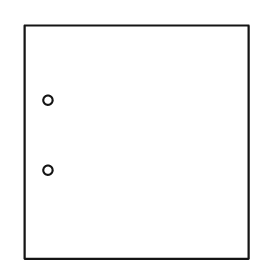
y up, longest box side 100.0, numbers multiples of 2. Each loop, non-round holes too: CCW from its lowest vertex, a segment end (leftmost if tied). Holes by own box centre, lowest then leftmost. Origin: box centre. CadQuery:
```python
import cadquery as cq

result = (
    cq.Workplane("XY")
    .moveTo(-48.0, -50.0)
    .lineTo(48.0, -50.0)
    .lineTo(48.0, 50.0)
    .lineTo(-48.0, 50.0)
    .close()
    .moveTo(-38.0, -12.0)
    .circle(2.0)
    .moveTo(-38.0, 18.0)
    .circle(2.0)
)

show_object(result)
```